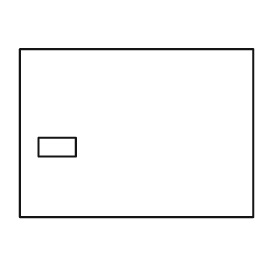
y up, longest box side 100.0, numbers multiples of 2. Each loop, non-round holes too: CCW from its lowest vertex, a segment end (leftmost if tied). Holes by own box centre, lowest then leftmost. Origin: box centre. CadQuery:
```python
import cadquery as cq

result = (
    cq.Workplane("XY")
    .moveTo(-50.0, -36.0)
    .lineTo(50.0, -36.0)
    .lineTo(50.0, 36.0)
    .lineTo(-50.0, 36.0)
    .close()
    .moveTo(-42.0, -10.0)
    .lineTo(-26.0, -10.0)
    .lineTo(-26.0, -2.0)
    .lineTo(-42.0, -2.0)
    .close()
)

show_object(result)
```